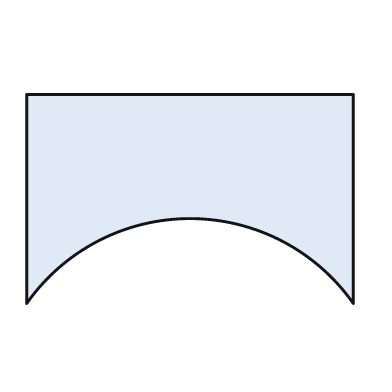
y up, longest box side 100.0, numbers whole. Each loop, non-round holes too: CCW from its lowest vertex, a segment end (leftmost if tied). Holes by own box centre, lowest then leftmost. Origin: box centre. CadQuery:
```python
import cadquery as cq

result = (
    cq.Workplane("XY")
    .moveTo(-50.0, -32.0)
    .threePointArc((0.0, -6.0), (50.0, -32.0))
    .lineTo(50.0, 32.0)
    .lineTo(-50.0, 32.0)
    .close()
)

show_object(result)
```